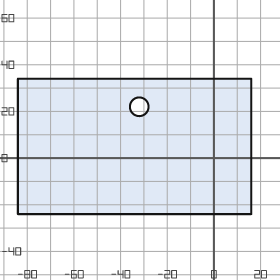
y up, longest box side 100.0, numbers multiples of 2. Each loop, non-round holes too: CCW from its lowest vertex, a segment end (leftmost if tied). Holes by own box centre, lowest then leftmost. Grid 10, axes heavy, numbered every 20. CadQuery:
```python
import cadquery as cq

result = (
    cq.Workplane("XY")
    .moveTo(-84.0, -24.0)
    .lineTo(16.0, -24.0)
    .lineTo(16.0, 34.0)
    .lineTo(-84.0, 34.0)
    .close()
    .moveTo(-32.0, 22.0)
    .circle(4.0)
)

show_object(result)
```